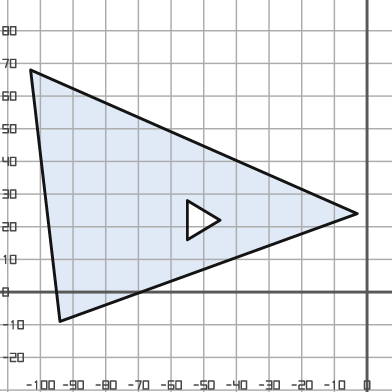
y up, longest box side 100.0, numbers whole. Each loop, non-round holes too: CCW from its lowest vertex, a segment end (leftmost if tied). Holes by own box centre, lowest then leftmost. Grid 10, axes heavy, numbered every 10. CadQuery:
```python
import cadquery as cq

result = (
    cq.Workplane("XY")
    .moveTo(-94.0, -9.0)
    .lineTo(-3.0, 24.0)
    .lineTo(-103.0, 68.0)
    .close()
    .moveTo(-55.0, 16.0)
    .lineTo(-45.0, 22.0)
    .lineTo(-55.0, 28.0)
    .close()
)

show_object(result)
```